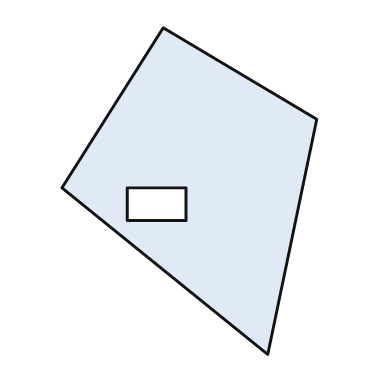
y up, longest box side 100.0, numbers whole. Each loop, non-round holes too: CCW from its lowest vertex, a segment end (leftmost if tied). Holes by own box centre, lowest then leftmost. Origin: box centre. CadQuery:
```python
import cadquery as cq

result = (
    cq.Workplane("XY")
    .moveTo(24.0, -50.0)
    .lineTo(39.0, 22.0)
    .lineTo(-8.0, 50.0)
    .lineTo(-39.0, 1.0)
    .close()
    .moveTo(-19.0, -9.0)
    .lineTo(-1.0, -9.0)
    .lineTo(-1.0, 1.0)
    .lineTo(-19.0, 1.0)
    .close()
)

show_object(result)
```